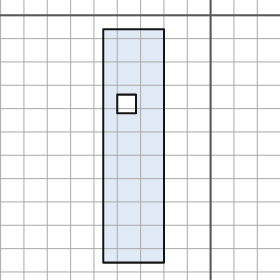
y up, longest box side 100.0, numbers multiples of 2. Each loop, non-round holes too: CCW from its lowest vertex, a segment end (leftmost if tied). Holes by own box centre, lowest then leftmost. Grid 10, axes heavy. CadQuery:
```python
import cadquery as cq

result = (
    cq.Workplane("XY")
    .moveTo(-46.0, -106.0)
    .lineTo(-20.0, -106.0)
    .lineTo(-20.0, -6.0)
    .lineTo(-46.0, -6.0)
    .close()
    .moveTo(-40.0, -42.0)
    .lineTo(-32.0, -42.0)
    .lineTo(-32.0, -34.0)
    .lineTo(-40.0, -34.0)
    .close()
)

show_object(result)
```